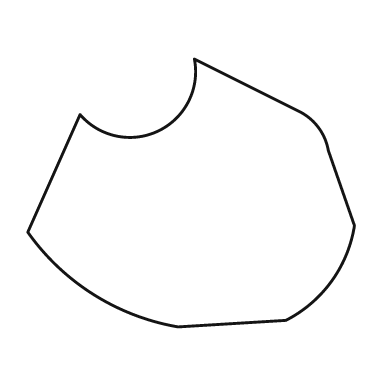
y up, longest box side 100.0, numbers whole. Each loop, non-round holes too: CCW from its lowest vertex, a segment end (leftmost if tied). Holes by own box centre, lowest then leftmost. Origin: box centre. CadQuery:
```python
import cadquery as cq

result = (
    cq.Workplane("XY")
    .moveTo(-4.0, -41.0)
    .lineTo(29.0, -39.0)
    .threePointArc((43.0, -27.0), (50.0, -10.0))
    .lineTo(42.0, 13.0)
    .threePointArc((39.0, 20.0), (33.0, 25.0))
    .lineTo(1.0, 41.0)
    .threePointArc((-10.0, 19.0), (-34.0, 24.0))
    .lineTo(-50.0, -12.0)
    .threePointArc((-30.0, -31.0), (-4.0, -41.0))
    .close()
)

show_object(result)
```